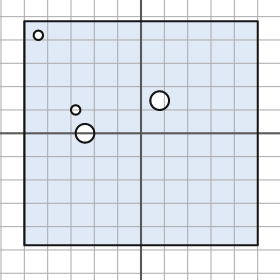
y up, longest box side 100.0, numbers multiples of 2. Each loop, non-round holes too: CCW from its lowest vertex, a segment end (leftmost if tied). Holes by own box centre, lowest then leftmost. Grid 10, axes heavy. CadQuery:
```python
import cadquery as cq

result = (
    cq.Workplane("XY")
    .moveTo(-50.0, -48.0)
    .lineTo(50.0, -48.0)
    .lineTo(50.0, 48.0)
    .lineTo(-50.0, 48.0)
    .close()
    .moveTo(-24.0, 0.0)
    .circle(4.0)
    .moveTo(-28.0, 10.0)
    .circle(2.0)
    .moveTo(8.0, 14.0)
    .circle(4.0)
    .moveTo(-44.0, 42.0)
    .circle(2.0)
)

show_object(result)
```